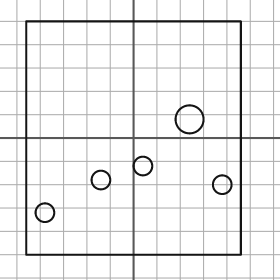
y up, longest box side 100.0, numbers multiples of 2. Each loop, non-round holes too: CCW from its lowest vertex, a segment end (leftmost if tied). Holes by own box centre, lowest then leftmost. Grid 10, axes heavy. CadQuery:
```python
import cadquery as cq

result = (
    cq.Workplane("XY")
    .moveTo(-46.0, -50.0)
    .lineTo(46.0, -50.0)
    .lineTo(46.0, 50.0)
    .lineTo(-46.0, 50.0)
    .close()
    .moveTo(-38.0, -32.0)
    .circle(4.0)
    .moveTo(38.0, -20.0)
    .circle(4.0)
    .moveTo(-14.0, -18.0)
    .circle(4.0)
    .moveTo(4.0, -12.0)
    .circle(4.0)
    .moveTo(24.0, 8.0)
    .circle(6.0)
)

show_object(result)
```